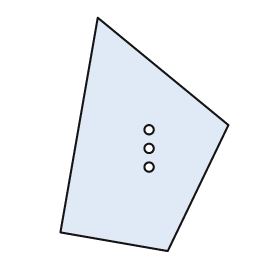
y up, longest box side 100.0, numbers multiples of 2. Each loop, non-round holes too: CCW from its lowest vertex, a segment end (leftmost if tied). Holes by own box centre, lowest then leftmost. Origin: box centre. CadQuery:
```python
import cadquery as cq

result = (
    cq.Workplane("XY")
    .moveTo(10.0, -50.0)
    .lineTo(36.0, 4.0)
    .lineTo(-20.0, 50.0)
    .lineTo(-36.0, -42.0)
    .close()
    .moveTo(2.0, -14.0)
    .circle(2.0)
    .moveTo(2.0, -6.0)
    .circle(2.0)
    .moveTo(2.0, 2.0)
    .circle(2.0)
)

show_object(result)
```